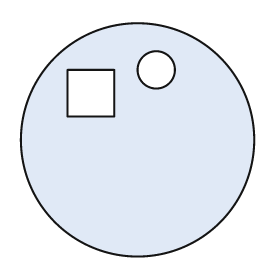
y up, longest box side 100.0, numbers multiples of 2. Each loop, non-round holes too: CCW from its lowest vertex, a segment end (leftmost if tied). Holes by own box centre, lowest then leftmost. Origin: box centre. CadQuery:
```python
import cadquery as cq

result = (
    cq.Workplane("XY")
    .moveTo(0.0, 0.0)
    .circle(50.0)
    .moveTo(-30.0, 10.0)
    .lineTo(-10.0, 10.0)
    .lineTo(-10.0, 30.0)
    .lineTo(-30.0, 30.0)
    .close()
    .moveTo(8.0, 30.0)
    .circle(8.0)
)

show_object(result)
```